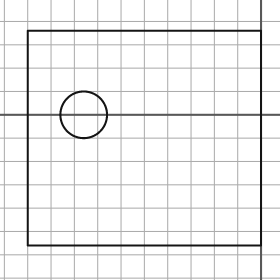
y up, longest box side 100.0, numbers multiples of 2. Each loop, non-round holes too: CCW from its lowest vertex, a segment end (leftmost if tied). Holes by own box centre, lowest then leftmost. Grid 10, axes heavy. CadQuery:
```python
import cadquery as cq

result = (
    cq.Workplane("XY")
    .moveTo(-100.0, -56.0)
    .lineTo(0.0, -56.0)
    .lineTo(0.0, 36.0)
    .lineTo(-100.0, 36.0)
    .close()
    .moveTo(-76.0, 0.0)
    .circle(10.0)
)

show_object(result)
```